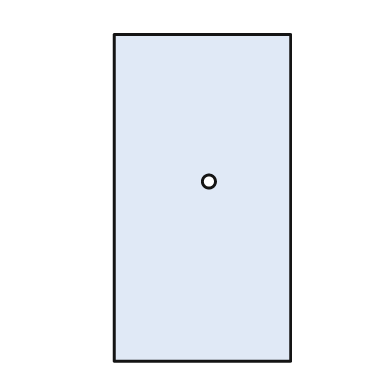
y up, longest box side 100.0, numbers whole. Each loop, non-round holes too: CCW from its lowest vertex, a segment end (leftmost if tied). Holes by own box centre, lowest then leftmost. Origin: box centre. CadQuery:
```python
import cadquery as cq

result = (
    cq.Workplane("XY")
    .moveTo(-27.0, -50.0)
    .lineTo(27.0, -50.0)
    .lineTo(27.0, 50.0)
    .lineTo(-27.0, 50.0)
    .close()
    .moveTo(2.0, 5.0)
    .circle(2.0)
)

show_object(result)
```